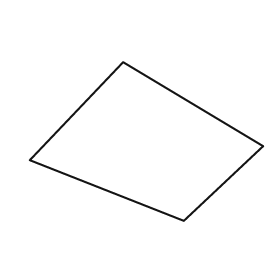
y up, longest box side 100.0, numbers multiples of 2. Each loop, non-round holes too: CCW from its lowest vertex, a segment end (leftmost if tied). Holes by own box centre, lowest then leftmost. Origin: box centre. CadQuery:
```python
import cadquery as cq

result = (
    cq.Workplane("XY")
    .moveTo(16.0, -34.0)
    .lineTo(50.0, -2.0)
    .lineTo(-10.0, 34.0)
    .lineTo(-50.0, -8.0)
    .close()
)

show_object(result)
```